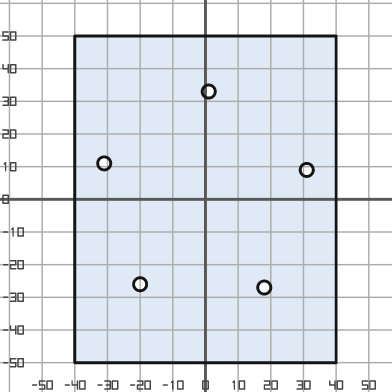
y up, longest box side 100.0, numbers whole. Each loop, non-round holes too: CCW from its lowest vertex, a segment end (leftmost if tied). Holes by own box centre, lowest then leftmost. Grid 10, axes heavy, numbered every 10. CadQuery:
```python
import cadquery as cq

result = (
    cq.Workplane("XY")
    .moveTo(-40.0, -50.0)
    .lineTo(40.0, -50.0)
    .lineTo(40.0, 50.0)
    .lineTo(-40.0, 50.0)
    .close()
    .moveTo(18.0, -27.0)
    .circle(2.0)
    .moveTo(-20.0, -26.0)
    .circle(2.0)
    .moveTo(31.0, 9.0)
    .circle(2.0)
    .moveTo(-31.0, 11.0)
    .circle(2.0)
    .moveTo(1.0, 33.0)
    .circle(2.0)
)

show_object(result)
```